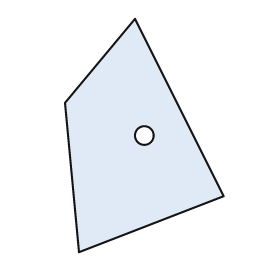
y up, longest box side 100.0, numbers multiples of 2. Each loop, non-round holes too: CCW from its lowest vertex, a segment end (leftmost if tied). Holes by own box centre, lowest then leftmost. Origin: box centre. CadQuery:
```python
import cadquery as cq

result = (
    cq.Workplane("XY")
    .moveTo(-28.0, -50.0)
    .lineTo(34.0, -26.0)
    .lineTo(-4.0, 50.0)
    .lineTo(-34.0, 14.0)
    .close()
    .moveTo(0.0, 0.0)
    .circle(4.0)
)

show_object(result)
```